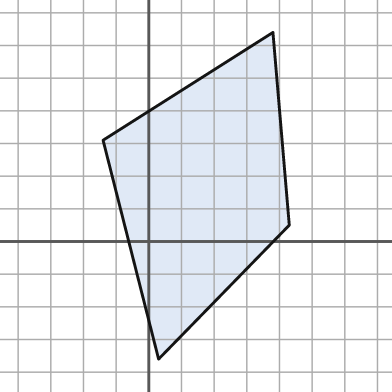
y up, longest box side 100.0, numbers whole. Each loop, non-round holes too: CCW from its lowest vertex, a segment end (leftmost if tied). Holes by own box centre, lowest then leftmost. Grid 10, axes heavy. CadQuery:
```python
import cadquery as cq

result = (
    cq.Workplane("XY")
    .moveTo(3.0, -36.0)
    .lineTo(43.0, 5.0)
    .lineTo(38.0, 64.0)
    .lineTo(-14.0, 31.0)
    .close()
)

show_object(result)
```